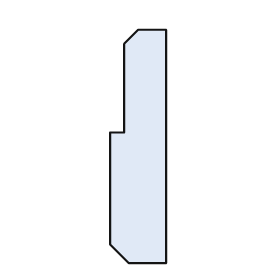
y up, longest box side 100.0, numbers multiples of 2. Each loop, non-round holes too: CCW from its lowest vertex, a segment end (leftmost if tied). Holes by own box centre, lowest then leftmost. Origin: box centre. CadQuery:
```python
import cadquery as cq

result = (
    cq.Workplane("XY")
    .moveTo(-4.0, -50.0)
    .lineTo(12.0, -50.0)
    .lineTo(12.0, 50.0)
    .lineTo(0.0, 50.0)
    .lineTo(-6.0, 44.0)
    .lineTo(-6.0, 6.0)
    .lineTo(-12.0, 6.0)
    .lineTo(-12.0, -42.0)
    .close()
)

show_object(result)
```